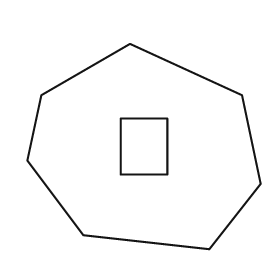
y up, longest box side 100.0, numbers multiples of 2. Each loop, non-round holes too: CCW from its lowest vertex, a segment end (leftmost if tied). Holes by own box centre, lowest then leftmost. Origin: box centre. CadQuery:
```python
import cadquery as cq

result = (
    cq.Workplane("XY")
    .moveTo(28.0, -44.0)
    .lineTo(50.0, -16.0)
    .lineTo(42.0, 22.0)
    .lineTo(-6.0, 44.0)
    .lineTo(-44.0, 22.0)
    .lineTo(-50.0, -6.0)
    .lineTo(-26.0, -38.0)
    .close()
    .moveTo(-10.0, -12.0)
    .lineTo(10.0, -12.0)
    .lineTo(10.0, 12.0)
    .lineTo(-10.0, 12.0)
    .close()
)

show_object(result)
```